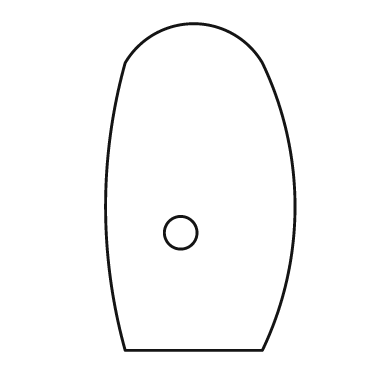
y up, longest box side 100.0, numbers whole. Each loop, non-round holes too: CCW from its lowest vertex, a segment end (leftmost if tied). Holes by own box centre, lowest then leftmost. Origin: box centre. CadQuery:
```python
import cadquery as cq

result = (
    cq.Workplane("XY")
    .moveTo(-23.0, -50.0)
    .lineTo(19.0, -50.0)
    .threePointArc((29.0, -6.0), (19.0, 38.0))
    .threePointArc((-2.0, 50.0), (-23.0, 38.0))
    .threePointArc((-29.0, -6.0), (-23.0, -50.0))
    .close()
    .moveTo(-6.0, -14.0)
    .circle(5.0)
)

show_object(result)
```